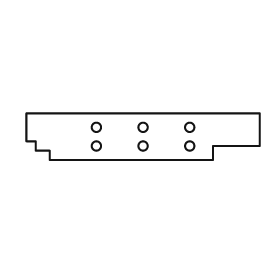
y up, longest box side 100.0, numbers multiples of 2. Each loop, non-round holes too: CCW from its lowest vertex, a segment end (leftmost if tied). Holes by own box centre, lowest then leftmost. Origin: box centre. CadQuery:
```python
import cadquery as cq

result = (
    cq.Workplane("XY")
    .moveTo(-40.0, -10.0)
    .lineTo(30.0, -10.0)
    .lineTo(30.0, -4.0)
    .lineTo(50.0, -4.0)
    .lineTo(50.0, 10.0)
    .lineTo(-50.0, 10.0)
    .lineTo(-50.0, -2.0)
    .lineTo(-46.0, -2.0)
    .lineTo(-46.0, -6.0)
    .lineTo(-40.0, -6.0)
    .close()
    .moveTo(-20.0, -4.0)
    .circle(2.0)
    .moveTo(0.0, -4.0)
    .circle(2.0)
    .moveTo(20.0, -4.0)
    .circle(2.0)
    .moveTo(-20.0, 4.0)
    .circle(2.0)
    .moveTo(0.0, 4.0)
    .circle(2.0)
    .moveTo(20.0, 4.0)
    .circle(2.0)
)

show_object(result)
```